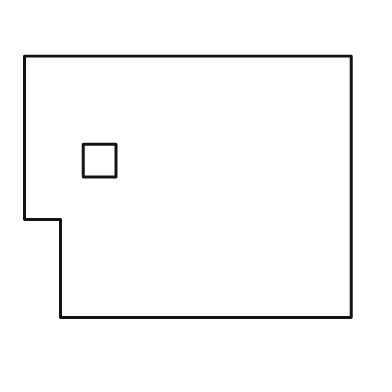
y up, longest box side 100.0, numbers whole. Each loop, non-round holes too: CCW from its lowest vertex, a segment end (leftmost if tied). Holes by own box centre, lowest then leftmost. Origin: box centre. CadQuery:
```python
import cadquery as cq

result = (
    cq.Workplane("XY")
    .moveTo(-39.0, -40.0)
    .lineTo(50.0, -40.0)
    .lineTo(50.0, 40.0)
    .lineTo(-50.0, 40.0)
    .lineTo(-50.0, -10.0)
    .lineTo(-39.0, -10.0)
    .close()
    .moveTo(-32.0, 3.0)
    .lineTo(-22.0, 3.0)
    .lineTo(-22.0, 13.0)
    .lineTo(-32.0, 13.0)
    .close()
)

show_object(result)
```